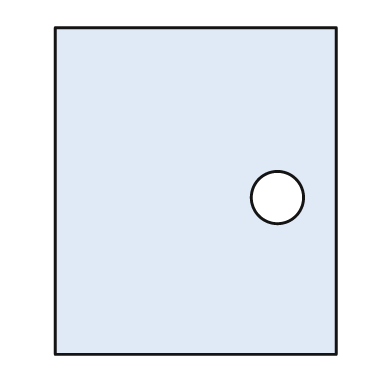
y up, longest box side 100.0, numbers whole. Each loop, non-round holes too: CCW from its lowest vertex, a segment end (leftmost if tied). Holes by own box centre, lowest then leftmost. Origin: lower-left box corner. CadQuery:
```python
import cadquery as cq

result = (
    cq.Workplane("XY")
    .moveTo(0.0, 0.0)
    .lineTo(86.0, 0.0)
    .lineTo(86.0, 100.0)
    .lineTo(0.0, 100.0)
    .close()
    .moveTo(68.0, 48.0)
    .circle(8.0)
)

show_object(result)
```